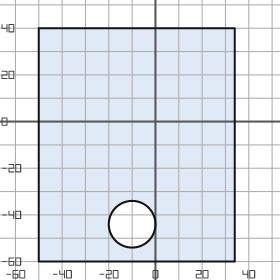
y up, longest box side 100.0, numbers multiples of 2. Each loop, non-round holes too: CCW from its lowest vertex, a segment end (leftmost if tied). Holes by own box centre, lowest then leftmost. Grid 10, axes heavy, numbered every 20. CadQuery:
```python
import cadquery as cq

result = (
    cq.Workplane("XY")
    .moveTo(-50.0, -60.0)
    .lineTo(34.0, -60.0)
    .lineTo(34.0, 40.0)
    .lineTo(-50.0, 40.0)
    .close()
    .moveTo(-10.0, -44.0)
    .circle(10.0)
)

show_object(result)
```